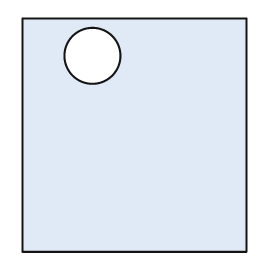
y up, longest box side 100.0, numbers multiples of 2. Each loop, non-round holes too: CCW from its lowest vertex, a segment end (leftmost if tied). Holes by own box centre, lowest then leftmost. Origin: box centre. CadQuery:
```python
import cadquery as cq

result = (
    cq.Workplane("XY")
    .moveTo(-48.0, -50.0)
    .lineTo(48.0, -50.0)
    .lineTo(48.0, 50.0)
    .lineTo(-48.0, 50.0)
    .close()
    .moveTo(-18.0, 34.0)
    .circle(12.0)
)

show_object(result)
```